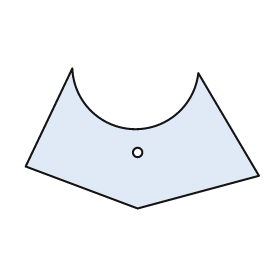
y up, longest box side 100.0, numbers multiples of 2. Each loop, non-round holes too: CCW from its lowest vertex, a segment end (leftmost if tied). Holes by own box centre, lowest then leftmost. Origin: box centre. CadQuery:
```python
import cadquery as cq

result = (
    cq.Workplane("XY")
    .moveTo(-2.0, -30.0)
    .lineTo(50.0, -16.0)
    .lineTo(24.0, 28.0)
    .threePointArc((-4.0, 4.0), (-30.0, 30.0))
    .lineTo(-50.0, -12.0)
    .close()
    .moveTo(-2.0, -6.0)
    .circle(2.0)
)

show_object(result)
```